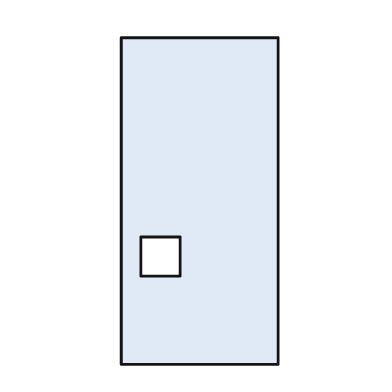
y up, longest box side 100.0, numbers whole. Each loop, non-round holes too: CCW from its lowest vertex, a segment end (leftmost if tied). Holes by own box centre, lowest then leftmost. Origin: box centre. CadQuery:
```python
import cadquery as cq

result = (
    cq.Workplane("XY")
    .moveTo(-24.0, -50.0)
    .lineTo(24.0, -50.0)
    .lineTo(24.0, 50.0)
    .lineTo(-24.0, 50.0)
    .close()
    .moveTo(-18.0, -23.0)
    .lineTo(-6.0, -23.0)
    .lineTo(-6.0, -11.0)
    .lineTo(-18.0, -11.0)
    .close()
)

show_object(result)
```